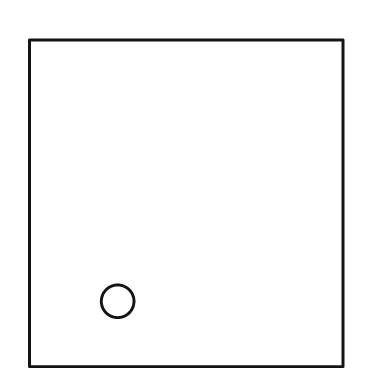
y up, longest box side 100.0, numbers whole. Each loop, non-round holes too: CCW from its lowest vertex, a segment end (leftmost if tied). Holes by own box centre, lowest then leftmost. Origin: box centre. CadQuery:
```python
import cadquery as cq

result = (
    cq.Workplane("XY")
    .moveTo(-48.0, -50.0)
    .lineTo(48.0, -50.0)
    .lineTo(48.0, 50.0)
    .lineTo(-48.0, 50.0)
    .close()
    .moveTo(-21.0, -30.0)
    .circle(5.0)
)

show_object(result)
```